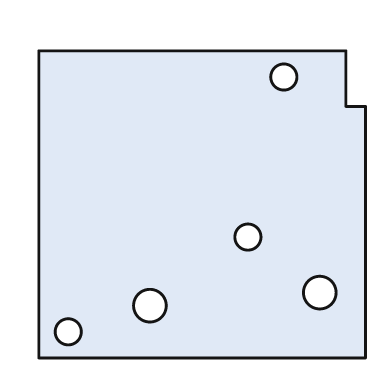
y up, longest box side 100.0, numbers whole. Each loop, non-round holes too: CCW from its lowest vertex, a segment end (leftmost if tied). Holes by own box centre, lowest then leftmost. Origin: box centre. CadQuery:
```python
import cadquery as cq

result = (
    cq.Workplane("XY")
    .moveTo(-50.0, -47.0)
    .lineTo(50.0, -47.0)
    .lineTo(50.0, 30.0)
    .lineTo(44.0, 30.0)
    .lineTo(44.0, 47.0)
    .lineTo(-50.0, 47.0)
    .close()
    .moveTo(-41.0, -39.0)
    .circle(4.0)
    .moveTo(-16.0, -31.0)
    .circle(5.0)
    .moveTo(36.0, -27.0)
    .circle(5.0)
    .moveTo(14.0, -10.0)
    .circle(4.0)
    .moveTo(25.0, 39.0)
    .circle(4.0)
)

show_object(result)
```